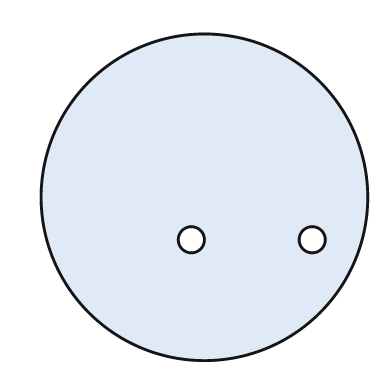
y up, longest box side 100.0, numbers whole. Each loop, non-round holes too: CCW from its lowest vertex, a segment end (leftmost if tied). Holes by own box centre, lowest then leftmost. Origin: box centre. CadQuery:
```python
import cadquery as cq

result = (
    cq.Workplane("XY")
    .moveTo(0.0, 0.0)
    .circle(50.0)
    .moveTo(-4.0, -13.0)
    .circle(4.0)
    .moveTo(33.0, -13.0)
    .circle(4.0)
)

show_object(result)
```